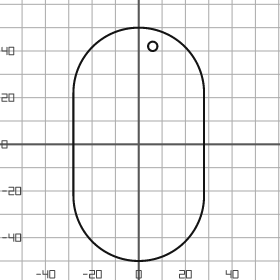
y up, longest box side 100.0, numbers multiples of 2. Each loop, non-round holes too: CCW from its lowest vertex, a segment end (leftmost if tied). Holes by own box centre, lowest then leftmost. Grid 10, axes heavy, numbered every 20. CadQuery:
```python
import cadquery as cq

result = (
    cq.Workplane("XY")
    .moveTo(-28.0, -22.0)
    .threePointArc((0.0, -50.0), (28.0, -22.0))
    .lineTo(28.0, 22.0)
    .threePointArc((0.0, 50.0), (-28.0, 22.0))
    .close()
    .moveTo(6.0, 42.0)
    .circle(2.0)
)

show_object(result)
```